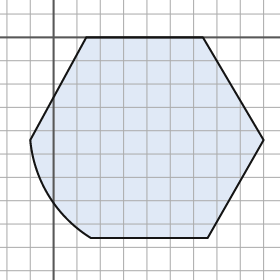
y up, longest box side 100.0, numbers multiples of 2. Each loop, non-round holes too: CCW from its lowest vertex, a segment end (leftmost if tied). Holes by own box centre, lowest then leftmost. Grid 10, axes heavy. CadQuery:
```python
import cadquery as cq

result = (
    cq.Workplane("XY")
    .moveTo(16.0, -86.0)
    .lineTo(66.0, -86.0)
    .lineTo(90.0, -44.0)
    .lineTo(64.0, 0.0)
    .lineTo(14.0, 0.0)
    .lineTo(-10.0, -44.0)
    .threePointArc((-2.0, -68.0), (16.0, -86.0))
    .close()
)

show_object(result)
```